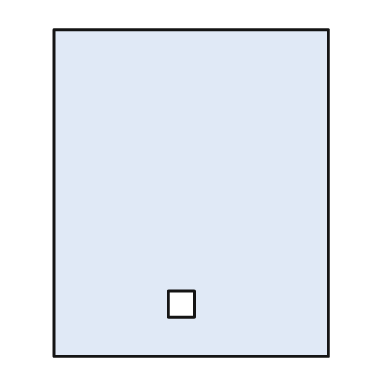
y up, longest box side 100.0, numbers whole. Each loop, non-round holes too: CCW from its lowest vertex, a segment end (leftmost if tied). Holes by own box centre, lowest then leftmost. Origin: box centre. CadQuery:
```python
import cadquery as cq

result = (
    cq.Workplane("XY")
    .moveTo(-42.0, -50.0)
    .lineTo(42.0, -50.0)
    .lineTo(42.0, 50.0)
    .lineTo(-42.0, 50.0)
    .close()
    .moveTo(-7.0, -38.0)
    .lineTo(1.0, -38.0)
    .lineTo(1.0, -30.0)
    .lineTo(-7.0, -30.0)
    .close()
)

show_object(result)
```